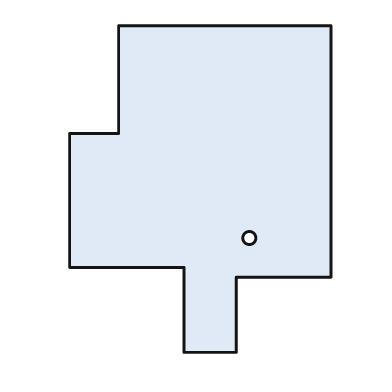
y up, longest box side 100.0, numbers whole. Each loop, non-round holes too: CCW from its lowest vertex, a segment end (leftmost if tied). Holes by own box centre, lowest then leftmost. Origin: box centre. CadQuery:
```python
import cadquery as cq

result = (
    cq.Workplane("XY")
    .moveTo(-5.0, -50.0)
    .lineTo(11.0, -50.0)
    .lineTo(11.0, -27.0)
    .lineTo(40.0, -27.0)
    .lineTo(40.0, 50.0)
    .lineTo(-25.0, 50.0)
    .lineTo(-25.0, 17.0)
    .lineTo(-40.0, 17.0)
    .lineTo(-40.0, -24.0)
    .lineTo(-5.0, -24.0)
    .close()
    .moveTo(15.0, -15.0)
    .circle(2.0)
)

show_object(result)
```